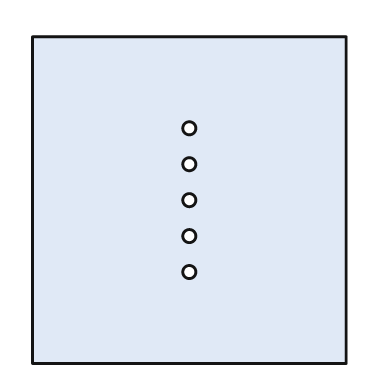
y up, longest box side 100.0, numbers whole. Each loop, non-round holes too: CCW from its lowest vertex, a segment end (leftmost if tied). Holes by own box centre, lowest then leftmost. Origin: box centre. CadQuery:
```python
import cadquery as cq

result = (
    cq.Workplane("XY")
    .moveTo(-48.0, -50.0)
    .lineTo(48.0, -50.0)
    .lineTo(48.0, 50.0)
    .lineTo(-48.0, 50.0)
    .close()
    .moveTo(0.0, -22.0)
    .circle(2.0)
    .moveTo(0.0, -11.0)
    .circle(2.0)
    .moveTo(0.0, 0.0)
    .circle(2.0)
    .moveTo(0.0, 11.0)
    .circle(2.0)
    .moveTo(0.0, 22.0)
    .circle(2.0)
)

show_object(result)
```